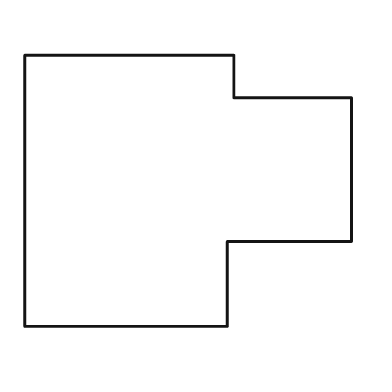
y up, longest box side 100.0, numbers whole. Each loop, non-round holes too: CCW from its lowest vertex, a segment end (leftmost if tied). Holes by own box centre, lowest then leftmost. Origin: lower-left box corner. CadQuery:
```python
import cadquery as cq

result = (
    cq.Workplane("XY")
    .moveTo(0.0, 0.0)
    .lineTo(62.0, 0.0)
    .lineTo(62.0, 26.0)
    .lineTo(100.0, 26.0)
    .lineTo(100.0, 70.0)
    .lineTo(64.0, 70.0)
    .lineTo(64.0, 83.0)
    .lineTo(0.0, 83.0)
    .close()
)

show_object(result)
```